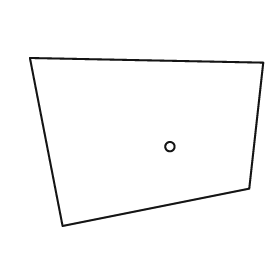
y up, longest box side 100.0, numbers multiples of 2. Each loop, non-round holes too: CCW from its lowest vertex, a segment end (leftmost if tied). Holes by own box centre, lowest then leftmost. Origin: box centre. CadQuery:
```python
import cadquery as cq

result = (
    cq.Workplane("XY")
    .moveTo(-36.0, -36.0)
    .lineTo(44.0, -20.0)
    .lineTo(50.0, 34.0)
    .lineTo(-50.0, 36.0)
    .close()
    .moveTo(10.0, -2.0)
    .circle(2.0)
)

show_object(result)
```